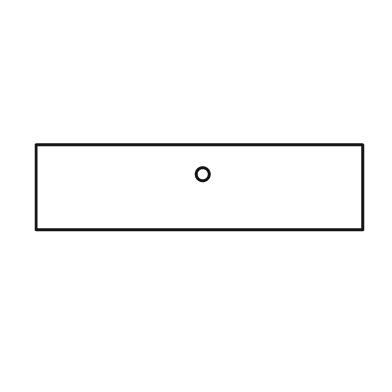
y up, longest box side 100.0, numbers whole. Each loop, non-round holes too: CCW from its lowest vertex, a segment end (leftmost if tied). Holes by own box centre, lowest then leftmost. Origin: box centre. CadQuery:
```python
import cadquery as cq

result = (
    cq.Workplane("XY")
    .moveTo(-50.0, -13.0)
    .lineTo(50.0, -13.0)
    .lineTo(50.0, 13.0)
    .lineTo(-50.0, 13.0)
    .close()
    .moveTo(1.0, 4.0)
    .circle(2.0)
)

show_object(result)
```